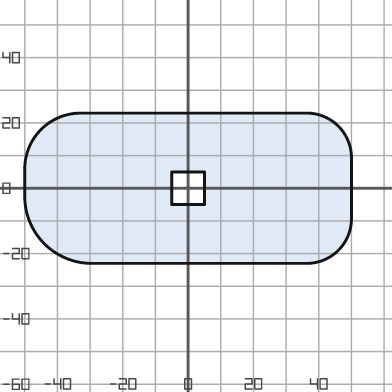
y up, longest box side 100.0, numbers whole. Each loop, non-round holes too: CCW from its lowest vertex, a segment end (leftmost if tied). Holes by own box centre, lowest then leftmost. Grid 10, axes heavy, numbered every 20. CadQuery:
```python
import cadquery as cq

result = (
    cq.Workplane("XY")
    .moveTo(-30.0, -23.0)
    .lineTo(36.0, -23.0)
    .threePointArc((46.0, -19.0), (50.0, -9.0))
    .lineTo(50.0, 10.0)
    .threePointArc((46.0, 19.0), (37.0, 23.0))
    .lineTo(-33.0, 23.0)
    .threePointArc((-45.0, 18.0), (-50.0, 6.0))
    .lineTo(-50.0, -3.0)
    .threePointArc((-44.0, -17.0), (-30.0, -23.0))
    .close()
    .moveTo(-5.0, -5.0)
    .lineTo(5.0, -5.0)
    .lineTo(5.0, 5.0)
    .lineTo(-5.0, 5.0)
    .close()
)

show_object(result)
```